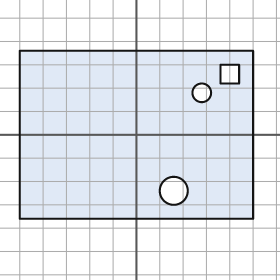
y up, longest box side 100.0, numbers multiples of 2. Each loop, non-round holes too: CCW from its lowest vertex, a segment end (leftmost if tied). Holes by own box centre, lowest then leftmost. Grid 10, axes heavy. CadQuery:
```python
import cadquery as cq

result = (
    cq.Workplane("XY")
    .moveTo(-50.0, -36.0)
    .lineTo(50.0, -36.0)
    .lineTo(50.0, 36.0)
    .lineTo(-50.0, 36.0)
    .close()
    .moveTo(16.0, -24.0)
    .circle(6.0)
    .moveTo(28.0, 18.0)
    .circle(4.0)
    .moveTo(36.0, 22.0)
    .lineTo(44.0, 22.0)
    .lineTo(44.0, 30.0)
    .lineTo(36.0, 30.0)
    .close()
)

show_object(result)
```